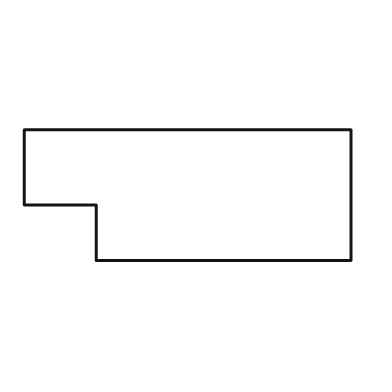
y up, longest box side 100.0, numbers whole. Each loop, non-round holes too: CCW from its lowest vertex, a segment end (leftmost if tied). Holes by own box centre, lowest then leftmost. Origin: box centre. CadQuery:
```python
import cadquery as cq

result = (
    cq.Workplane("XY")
    .moveTo(-28.0, -20.0)
    .lineTo(50.0, -20.0)
    .lineTo(50.0, 20.0)
    .lineTo(-50.0, 20.0)
    .lineTo(-50.0, -3.0)
    .lineTo(-28.0, -3.0)
    .close()
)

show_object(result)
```